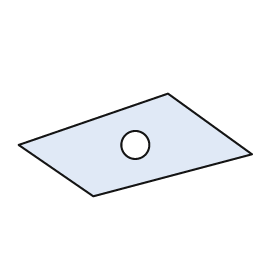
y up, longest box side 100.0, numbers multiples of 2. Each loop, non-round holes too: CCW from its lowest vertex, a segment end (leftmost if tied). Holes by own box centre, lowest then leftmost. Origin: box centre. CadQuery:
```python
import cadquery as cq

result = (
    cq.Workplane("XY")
    .moveTo(-18.0, -22.0)
    .lineTo(50.0, -4.0)
    .lineTo(14.0, 22.0)
    .lineTo(-50.0, 0.0)
    .close()
    .moveTo(0.0, 0.0)
    .circle(6.0)
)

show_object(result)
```